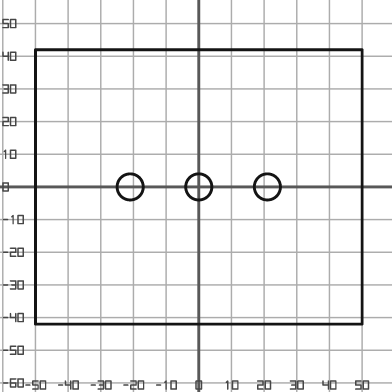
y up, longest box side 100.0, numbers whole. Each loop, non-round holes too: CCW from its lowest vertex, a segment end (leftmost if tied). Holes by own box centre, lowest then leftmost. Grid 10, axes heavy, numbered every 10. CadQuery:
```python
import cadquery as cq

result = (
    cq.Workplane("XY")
    .moveTo(-50.0, -42.0)
    .lineTo(50.0, -42.0)
    .lineTo(50.0, 42.0)
    .lineTo(-50.0, 42.0)
    .close()
    .moveTo(-21.0, 0.0)
    .circle(4.0)
    .moveTo(0.0, 0.0)
    .circle(4.0)
    .moveTo(21.0, 0.0)
    .circle(4.0)
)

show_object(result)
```